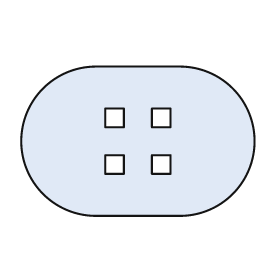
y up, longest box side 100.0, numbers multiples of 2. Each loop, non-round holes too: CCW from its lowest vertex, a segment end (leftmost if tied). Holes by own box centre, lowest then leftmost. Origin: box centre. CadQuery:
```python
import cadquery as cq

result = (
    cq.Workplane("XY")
    .moveTo(-18.0, -32.0)
    .lineTo(18.0, -32.0)
    .threePointArc((50.0, 0.0), (18.0, 32.0))
    .lineTo(-18.0, 32.0)
    .threePointArc((-50.0, 0.0), (-18.0, -32.0))
    .close()
    .moveTo(-14.0, -14.0)
    .lineTo(-6.0, -14.0)
    .lineTo(-6.0, -6.0)
    .lineTo(-14.0, -6.0)
    .close()
    .moveTo(6.0, -14.0)
    .lineTo(14.0, -14.0)
    .lineTo(14.0, -6.0)
    .lineTo(6.0, -6.0)
    .close()
    .moveTo(-14.0, 6.0)
    .lineTo(-6.0, 6.0)
    .lineTo(-6.0, 14.0)
    .lineTo(-14.0, 14.0)
    .close()
    .moveTo(6.0, 6.0)
    .lineTo(14.0, 6.0)
    .lineTo(14.0, 14.0)
    .lineTo(6.0, 14.0)
    .close()
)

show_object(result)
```